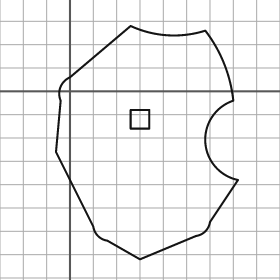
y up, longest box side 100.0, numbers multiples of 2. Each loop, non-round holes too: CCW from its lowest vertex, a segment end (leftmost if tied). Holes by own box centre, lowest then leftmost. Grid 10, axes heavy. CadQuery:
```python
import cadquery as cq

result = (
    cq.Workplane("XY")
    .moveTo(30.0, -72.0)
    .lineTo(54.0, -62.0)
    .threePointArc((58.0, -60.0), (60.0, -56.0))
    .lineTo(72.0, -38.0)
    .threePointArc((58.0, -22.0), (70.0, -4.0))
    .threePointArc((66.0, 12.0), (58.0, 26.0))
    .threePointArc((42.0, 24.0), (26.0, 28.0))
    .lineTo(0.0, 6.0)
    .threePointArc((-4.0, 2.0), (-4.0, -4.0))
    .lineTo(-6.0, -26.0)
    .lineTo(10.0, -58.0)
    .threePointArc((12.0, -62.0), (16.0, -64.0))
    .close()
    .moveTo(26.0, -16.0)
    .lineTo(34.0, -16.0)
    .lineTo(34.0, -8.0)
    .lineTo(26.0, -8.0)
    .close()
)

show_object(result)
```